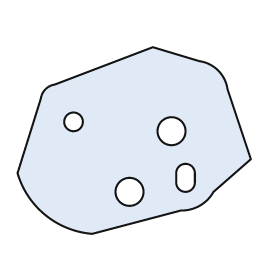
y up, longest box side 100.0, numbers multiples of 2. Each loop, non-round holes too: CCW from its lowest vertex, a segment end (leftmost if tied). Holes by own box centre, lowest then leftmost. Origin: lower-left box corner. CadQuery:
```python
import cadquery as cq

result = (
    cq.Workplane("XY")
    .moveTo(32.0, 0.0)
    .lineTo(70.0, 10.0)
    .threePointArc((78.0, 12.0), (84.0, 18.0))
    .lineTo(100.0, 32.0)
    .lineTo(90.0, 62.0)
    .threePointArc((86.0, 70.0), (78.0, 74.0))
    .lineTo(58.0, 80.0)
    .lineTo(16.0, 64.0)
    .threePointArc((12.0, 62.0), (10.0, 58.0))
    .lineTo(0.0, 26.0)
    .threePointArc((12.0, 8.0), (32.0, 0.0))
    .close()
    .moveTo(48.0, 18.0)
    .circle(6.0)
    .moveTo(68.0, 22.0)
    .threePointArc((72.0, 18.0), (76.0, 22.0))
    .lineTo(76.0, 26.0)
    .threePointArc((72.0, 30.0), (68.0, 26.0))
    .close()
    .moveTo(66.0, 44.0)
    .circle(6.0)
    .moveTo(24.0, 48.0)
    .circle(4.0)
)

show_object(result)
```